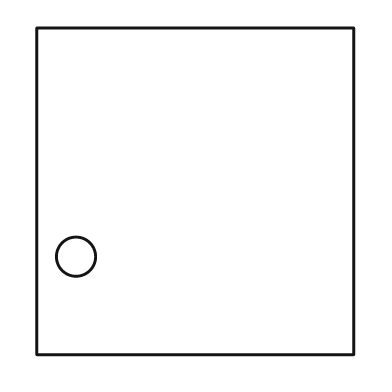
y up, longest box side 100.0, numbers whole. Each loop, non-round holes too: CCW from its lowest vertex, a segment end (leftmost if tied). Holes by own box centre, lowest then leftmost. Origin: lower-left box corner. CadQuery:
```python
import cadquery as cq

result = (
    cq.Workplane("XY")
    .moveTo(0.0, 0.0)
    .lineTo(97.0, 0.0)
    .lineTo(97.0, 100.0)
    .lineTo(0.0, 100.0)
    .close()
    .moveTo(12.0, 30.0)
    .circle(6.0)
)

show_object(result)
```